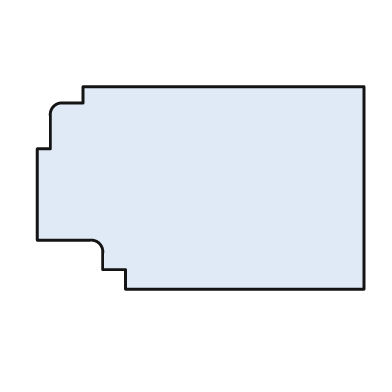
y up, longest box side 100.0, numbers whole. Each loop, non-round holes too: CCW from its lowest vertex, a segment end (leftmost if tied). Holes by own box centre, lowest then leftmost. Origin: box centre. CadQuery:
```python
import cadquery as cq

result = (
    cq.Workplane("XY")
    .moveTo(-23.0, -31.0)
    .lineTo(50.0, -31.0)
    .lineTo(50.0, 31.0)
    .lineTo(-36.0, 31.0)
    .lineTo(-36.0, 26.0)
    .lineTo(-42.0, 26.0)
    .threePointArc((-45.0, 25.0), (-46.0, 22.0))
    .lineTo(-46.0, 12.0)
    .lineTo(-50.0, 12.0)
    .lineTo(-50.0, -16.0)
    .lineTo(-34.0, -16.0)
    .threePointArc((-31.0, -17.0), (-30.0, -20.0))
    .lineTo(-30.0, -25.0)
    .lineTo(-23.0, -25.0)
    .close()
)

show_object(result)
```